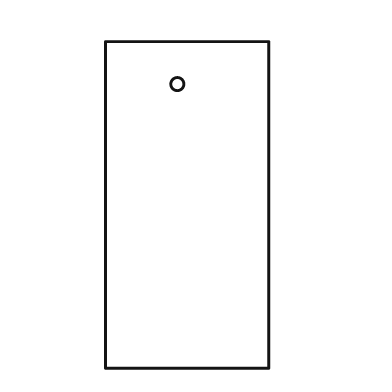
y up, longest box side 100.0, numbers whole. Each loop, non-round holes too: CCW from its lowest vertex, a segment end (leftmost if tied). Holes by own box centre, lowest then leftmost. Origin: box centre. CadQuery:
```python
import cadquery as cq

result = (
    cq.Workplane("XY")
    .moveTo(-25.0, -50.0)
    .lineTo(25.0, -50.0)
    .lineTo(25.0, 50.0)
    .lineTo(-25.0, 50.0)
    .close()
    .moveTo(-3.0, 37.0)
    .circle(2.0)
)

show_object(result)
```